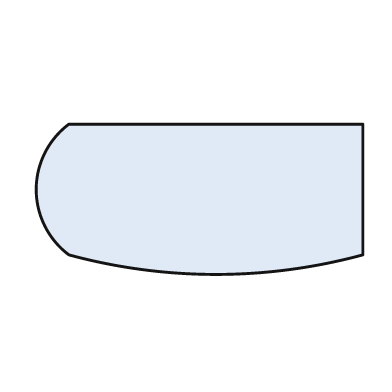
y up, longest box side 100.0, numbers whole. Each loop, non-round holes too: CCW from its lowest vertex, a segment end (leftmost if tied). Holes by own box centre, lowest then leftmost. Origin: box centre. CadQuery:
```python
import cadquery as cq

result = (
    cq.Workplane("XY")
    .moveTo(-40.0, -17.0)
    .threePointArc((5.0, -23.0), (50.0, -17.0))
    .lineTo(50.0, 23.0)
    .lineTo(-40.0, 23.0)
    .threePointArc((-50.0, 3.0), (-40.0, -17.0))
    .close()
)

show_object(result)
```